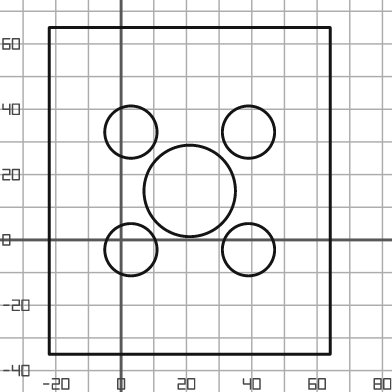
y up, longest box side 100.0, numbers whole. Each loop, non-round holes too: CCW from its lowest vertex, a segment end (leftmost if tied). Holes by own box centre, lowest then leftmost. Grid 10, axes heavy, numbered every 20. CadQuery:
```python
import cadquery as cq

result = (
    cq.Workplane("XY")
    .moveTo(-22.0, -35.0)
    .lineTo(64.0, -35.0)
    .lineTo(64.0, 65.0)
    .lineTo(-22.0, 65.0)
    .close()
    .moveTo(3.0, -3.0)
    .circle(8.0)
    .moveTo(39.0, -3.0)
    .circle(8.0)
    .moveTo(21.0, 15.0)
    .circle(14.0)
    .moveTo(3.0, 33.0)
    .circle(8.0)
    .moveTo(39.0, 33.0)
    .circle(8.0)
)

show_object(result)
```